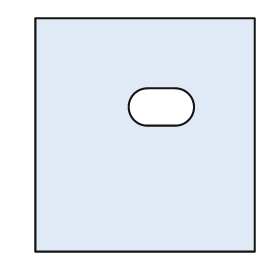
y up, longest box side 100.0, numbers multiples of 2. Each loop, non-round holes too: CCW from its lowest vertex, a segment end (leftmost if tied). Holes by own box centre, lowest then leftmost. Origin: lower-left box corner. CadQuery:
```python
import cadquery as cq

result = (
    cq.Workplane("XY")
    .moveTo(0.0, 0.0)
    .lineTo(94.0, 0.0)
    .lineTo(94.0, 100.0)
    .lineTo(0.0, 100.0)
    .close()
    .moveTo(48.0, 54.0)
    .lineTo(60.0, 54.0)
    .threePointArc((68.0, 62.0), (60.0, 70.0))
    .lineTo(48.0, 70.0)
    .threePointArc((40.0, 62.0), (48.0, 54.0))
    .close()
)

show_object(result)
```